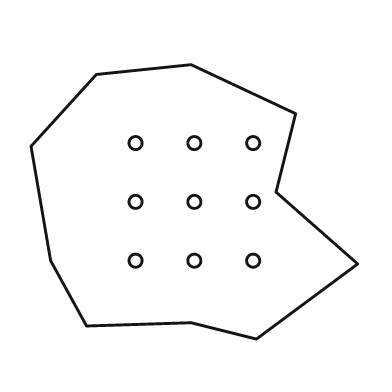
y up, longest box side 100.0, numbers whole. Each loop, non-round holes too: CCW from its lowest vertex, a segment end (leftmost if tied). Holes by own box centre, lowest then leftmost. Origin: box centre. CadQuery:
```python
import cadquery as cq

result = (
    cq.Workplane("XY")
    .moveTo(19.0, -42.0)
    .lineTo(50.0, -19.0)
    .lineTo(25.0, 3.0)
    .lineTo(31.0, 27.0)
    .lineTo(-1.0, 42.0)
    .lineTo(-30.0, 39.0)
    .lineTo(-50.0, 17.0)
    .lineTo(-44.0, -18.0)
    .lineTo(-33.0, -38.0)
    .lineTo(-1.0, -37.0)
    .close()
    .moveTo(-18.0, -18.0)
    .circle(2.0)
    .moveTo(0.0, -18.0)
    .circle(2.0)
    .moveTo(18.0, -18.0)
    .circle(2.0)
    .moveTo(-18.0, 0.0)
    .circle(2.0)
    .moveTo(0.0, 0.0)
    .circle(2.0)
    .moveTo(18.0, 0.0)
    .circle(2.0)
    .moveTo(-18.0, 18.0)
    .circle(2.0)
    .moveTo(0.0, 18.0)
    .circle(2.0)
    .moveTo(18.0, 18.0)
    .circle(2.0)
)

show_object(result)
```